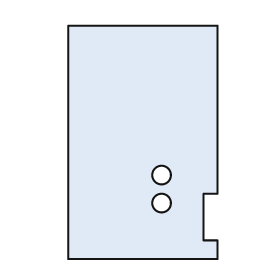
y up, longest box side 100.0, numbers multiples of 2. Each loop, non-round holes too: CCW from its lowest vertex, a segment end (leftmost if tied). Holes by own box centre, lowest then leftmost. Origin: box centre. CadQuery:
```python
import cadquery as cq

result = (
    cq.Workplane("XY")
    .moveTo(-32.0, -50.0)
    .lineTo(32.0, -50.0)
    .lineTo(32.0, -42.0)
    .lineTo(26.0, -42.0)
    .lineTo(26.0, -22.0)
    .lineTo(32.0, -22.0)
    .lineTo(32.0, 50.0)
    .lineTo(-32.0, 50.0)
    .close()
    .moveTo(8.0, -26.0)
    .circle(4.0)
    .moveTo(8.0, -14.0)
    .circle(4.0)
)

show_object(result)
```